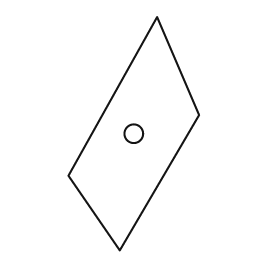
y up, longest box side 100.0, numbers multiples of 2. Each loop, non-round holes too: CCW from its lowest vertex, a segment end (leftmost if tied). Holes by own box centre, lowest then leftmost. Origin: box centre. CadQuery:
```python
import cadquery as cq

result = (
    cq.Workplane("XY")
    .moveTo(-6.0, -50.0)
    .lineTo(28.0, 8.0)
    .lineTo(10.0, 50.0)
    .lineTo(-28.0, -18.0)
    .close()
    .moveTo(0.0, 0.0)
    .circle(4.0)
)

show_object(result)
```